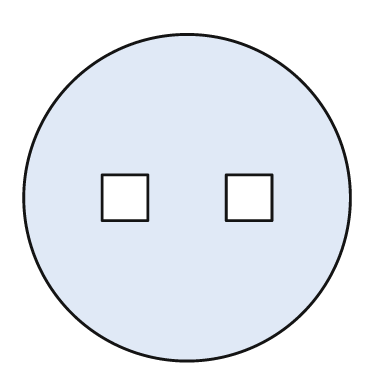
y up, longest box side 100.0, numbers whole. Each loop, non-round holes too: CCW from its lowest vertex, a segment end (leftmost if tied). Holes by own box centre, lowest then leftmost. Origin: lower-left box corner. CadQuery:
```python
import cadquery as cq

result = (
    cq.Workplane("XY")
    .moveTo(50.0, 50.0)
    .circle(50.0)
    .moveTo(24.0, 43.0)
    .lineTo(38.0, 43.0)
    .lineTo(38.0, 57.0)
    .lineTo(24.0, 57.0)
    .close()
    .moveTo(62.0, 43.0)
    .lineTo(76.0, 43.0)
    .lineTo(76.0, 57.0)
    .lineTo(62.0, 57.0)
    .close()
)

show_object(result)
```